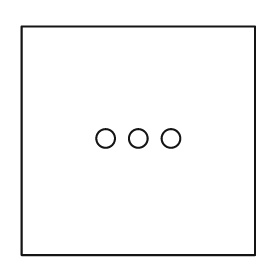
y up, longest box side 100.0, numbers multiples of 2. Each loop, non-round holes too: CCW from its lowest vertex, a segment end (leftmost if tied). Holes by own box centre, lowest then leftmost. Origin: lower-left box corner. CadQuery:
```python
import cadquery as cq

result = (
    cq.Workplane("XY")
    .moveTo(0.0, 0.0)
    .lineTo(100.0, 0.0)
    .lineTo(100.0, 98.0)
    .lineTo(0.0, 98.0)
    .close()
    .moveTo(36.0, 50.0)
    .circle(4.0)
    .moveTo(50.0, 50.0)
    .circle(4.0)
    .moveTo(64.0, 50.0)
    .circle(4.0)
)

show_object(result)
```